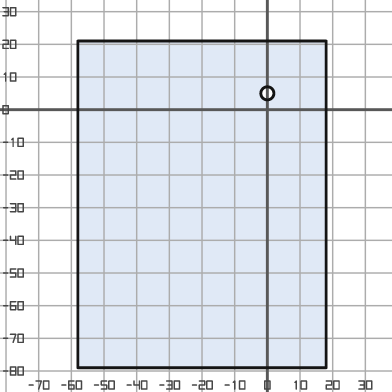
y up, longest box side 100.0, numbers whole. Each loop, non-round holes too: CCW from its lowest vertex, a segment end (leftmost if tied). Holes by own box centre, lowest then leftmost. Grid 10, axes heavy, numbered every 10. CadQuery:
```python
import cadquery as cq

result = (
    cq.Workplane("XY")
    .moveTo(-58.0, -79.0)
    .lineTo(18.0, -79.0)
    .lineTo(18.0, 21.0)
    .lineTo(-58.0, 21.0)
    .close()
    .moveTo(0.0, 5.0)
    .circle(2.0)
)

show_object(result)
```